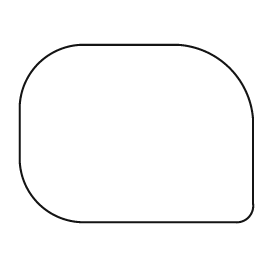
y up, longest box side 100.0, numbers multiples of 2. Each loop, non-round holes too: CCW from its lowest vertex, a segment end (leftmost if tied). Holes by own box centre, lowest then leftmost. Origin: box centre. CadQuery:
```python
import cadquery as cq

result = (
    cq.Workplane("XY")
    .moveTo(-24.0, -38.0)
    .lineTo(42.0, -38.0)
    .threePointArc((48.0, -36.0), (50.0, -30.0))
    .lineTo(50.0, 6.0)
    .threePointArc((40.0, 28.0), (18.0, 38.0))
    .lineTo(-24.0, 38.0)
    .threePointArc((-42.0, 30.0), (-50.0, 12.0))
    .lineTo(-50.0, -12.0)
    .threePointArc((-42.0, -30.0), (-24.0, -38.0))
    .close()
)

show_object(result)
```